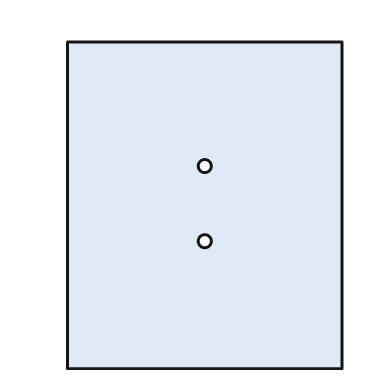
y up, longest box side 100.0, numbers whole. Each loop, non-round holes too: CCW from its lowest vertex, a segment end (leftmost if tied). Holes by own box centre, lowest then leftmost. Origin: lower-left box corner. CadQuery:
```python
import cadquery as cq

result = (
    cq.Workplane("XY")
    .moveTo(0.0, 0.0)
    .lineTo(84.0, 0.0)
    .lineTo(84.0, 100.0)
    .lineTo(0.0, 100.0)
    .close()
    .moveTo(42.0, 39.0)
    .circle(2.0)
    .moveTo(42.0, 62.0)
    .circle(2.0)
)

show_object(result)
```